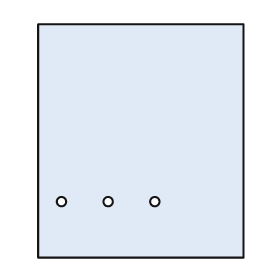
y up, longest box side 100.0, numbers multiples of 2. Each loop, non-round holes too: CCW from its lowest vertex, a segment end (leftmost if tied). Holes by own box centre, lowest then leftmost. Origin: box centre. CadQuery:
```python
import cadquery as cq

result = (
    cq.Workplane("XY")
    .moveTo(-44.0, -50.0)
    .lineTo(44.0, -50.0)
    .lineTo(44.0, 50.0)
    .lineTo(-44.0, 50.0)
    .close()
    .moveTo(-34.0, -26.0)
    .circle(2.0)
    .moveTo(-14.0, -26.0)
    .circle(2.0)
    .moveTo(6.0, -26.0)
    .circle(2.0)
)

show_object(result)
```